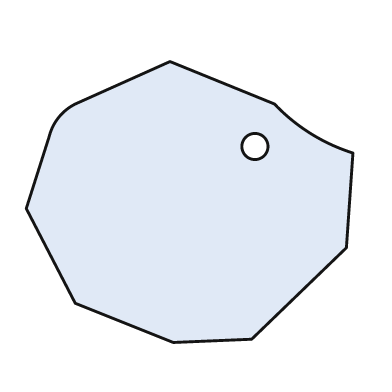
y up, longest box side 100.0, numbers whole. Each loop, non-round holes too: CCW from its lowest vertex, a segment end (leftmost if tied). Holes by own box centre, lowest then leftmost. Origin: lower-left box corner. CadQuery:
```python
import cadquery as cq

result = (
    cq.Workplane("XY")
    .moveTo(45.0, 0.0)
    .lineTo(69.0, 1.0)
    .lineTo(98.0, 29.0)
    .lineTo(100.0, 58.0)
    .threePointArc((87.0, 64.0), (76.0, 73.0))
    .lineTo(44.0, 86.0)
    .lineTo(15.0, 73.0)
    .threePointArc((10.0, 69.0), (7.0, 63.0))
    .lineTo(0.0, 41.0)
    .lineTo(15.0, 12.0)
    .close()
    .moveTo(70.0, 60.0)
    .circle(4.0)
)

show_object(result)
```